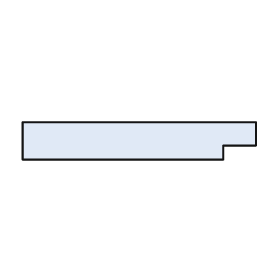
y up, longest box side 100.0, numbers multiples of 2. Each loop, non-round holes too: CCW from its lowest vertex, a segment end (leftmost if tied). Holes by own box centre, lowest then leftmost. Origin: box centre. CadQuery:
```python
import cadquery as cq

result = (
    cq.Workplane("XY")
    .moveTo(-50.0, -8.0)
    .lineTo(36.0, -8.0)
    .lineTo(36.0, -2.0)
    .lineTo(50.0, -2.0)
    .lineTo(50.0, 8.0)
    .lineTo(-50.0, 8.0)
    .close()
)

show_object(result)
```